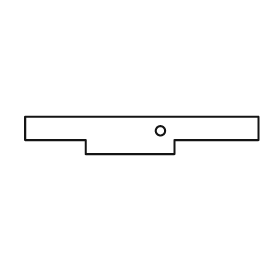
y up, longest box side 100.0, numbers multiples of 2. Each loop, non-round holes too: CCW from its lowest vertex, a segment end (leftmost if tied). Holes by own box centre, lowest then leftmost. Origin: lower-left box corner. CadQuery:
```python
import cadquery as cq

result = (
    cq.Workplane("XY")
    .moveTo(26.0, 0.0)
    .lineTo(64.0, 0.0)
    .lineTo(64.0, 6.0)
    .lineTo(100.0, 6.0)
    .lineTo(100.0, 16.0)
    .lineTo(0.0, 16.0)
    .lineTo(0.0, 6.0)
    .lineTo(26.0, 6.0)
    .close()
    .moveTo(58.0, 10.0)
    .circle(2.0)
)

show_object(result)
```